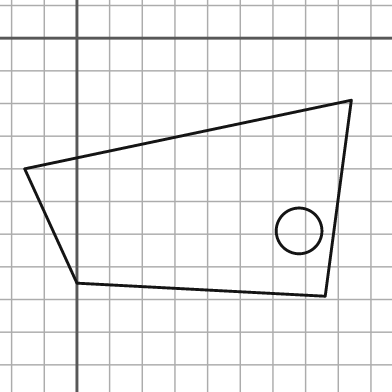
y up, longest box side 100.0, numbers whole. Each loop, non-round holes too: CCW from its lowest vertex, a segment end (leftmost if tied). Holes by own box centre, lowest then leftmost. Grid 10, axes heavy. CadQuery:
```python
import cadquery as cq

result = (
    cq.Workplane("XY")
    .moveTo(76.0, -79.0)
    .lineTo(84.0, -19.0)
    .lineTo(-16.0, -40.0)
    .lineTo(0.0, -75.0)
    .close()
    .moveTo(68.0, -59.0)
    .circle(7.0)
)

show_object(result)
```